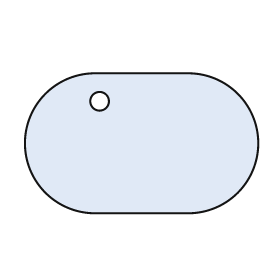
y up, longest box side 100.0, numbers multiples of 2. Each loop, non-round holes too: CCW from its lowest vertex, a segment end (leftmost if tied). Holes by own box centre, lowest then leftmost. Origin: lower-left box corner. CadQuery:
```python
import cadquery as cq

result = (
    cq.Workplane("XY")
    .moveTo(30.0, 0.0)
    .lineTo(70.0, 0.0)
    .threePointArc((100.0, 30.0), (70.0, 60.0))
    .lineTo(30.0, 60.0)
    .threePointArc((0.0, 30.0), (30.0, 0.0))
    .close()
    .moveTo(32.0, 48.0)
    .circle(4.0)
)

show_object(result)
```